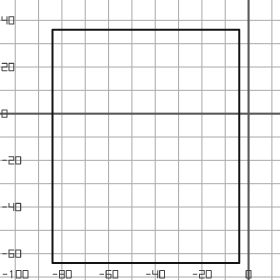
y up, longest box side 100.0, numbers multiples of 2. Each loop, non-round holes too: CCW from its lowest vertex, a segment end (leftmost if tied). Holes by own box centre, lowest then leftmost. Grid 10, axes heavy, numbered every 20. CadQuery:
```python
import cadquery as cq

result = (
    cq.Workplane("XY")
    .moveTo(-84.0, -64.0)
    .lineTo(-4.0, -64.0)
    .lineTo(-4.0, 36.0)
    .lineTo(-84.0, 36.0)
    .close()
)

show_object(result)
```